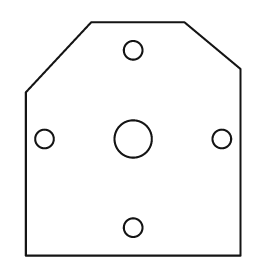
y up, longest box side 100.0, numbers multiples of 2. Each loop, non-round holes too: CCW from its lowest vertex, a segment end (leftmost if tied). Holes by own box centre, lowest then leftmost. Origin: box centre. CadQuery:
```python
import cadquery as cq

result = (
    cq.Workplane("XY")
    .moveTo(-46.0, -50.0)
    .lineTo(46.0, -50.0)
    .lineTo(46.0, 30.0)
    .lineTo(22.0, 50.0)
    .lineTo(-18.0, 50.0)
    .lineTo(-46.0, 20.0)
    .close()
    .moveTo(0.0, -38.0)
    .circle(4.0)
    .moveTo(-38.0, 0.0)
    .circle(4.0)
    .moveTo(0.0, 0.0)
    .circle(8.0)
    .moveTo(38.0, 0.0)
    .circle(4.0)
    .moveTo(0.0, 38.0)
    .circle(4.0)
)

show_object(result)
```